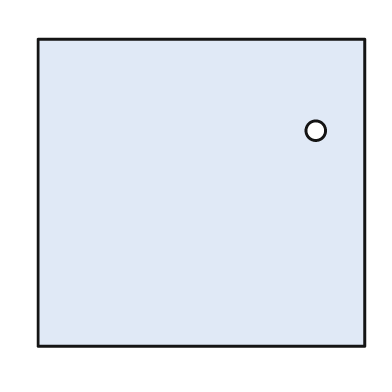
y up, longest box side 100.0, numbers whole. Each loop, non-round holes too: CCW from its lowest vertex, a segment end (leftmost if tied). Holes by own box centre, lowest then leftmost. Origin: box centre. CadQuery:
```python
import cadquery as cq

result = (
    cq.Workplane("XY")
    .moveTo(-50.0, -47.0)
    .lineTo(50.0, -47.0)
    .lineTo(50.0, 47.0)
    .lineTo(-50.0, 47.0)
    .close()
    .moveTo(35.0, 19.0)
    .circle(3.0)
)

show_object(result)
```